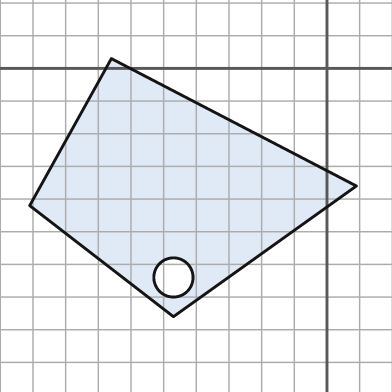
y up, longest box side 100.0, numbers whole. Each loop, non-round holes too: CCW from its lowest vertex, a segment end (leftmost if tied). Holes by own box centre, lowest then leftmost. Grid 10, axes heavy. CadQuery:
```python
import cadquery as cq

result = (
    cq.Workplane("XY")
    .moveTo(-47.0, -76.0)
    .lineTo(9.0, -36.0)
    .lineTo(-66.0, 3.0)
    .lineTo(-91.0, -42.0)
    .close()
    .moveTo(-47.0, -64.0)
    .circle(6.0)
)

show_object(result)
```